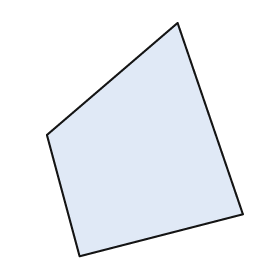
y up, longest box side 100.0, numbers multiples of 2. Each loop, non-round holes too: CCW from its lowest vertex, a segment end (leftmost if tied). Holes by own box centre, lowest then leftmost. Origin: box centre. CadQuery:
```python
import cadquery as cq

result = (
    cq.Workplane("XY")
    .moveTo(-28.0, -50.0)
    .lineTo(42.0, -32.0)
    .lineTo(14.0, 50.0)
    .lineTo(-42.0, 2.0)
    .close()
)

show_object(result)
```